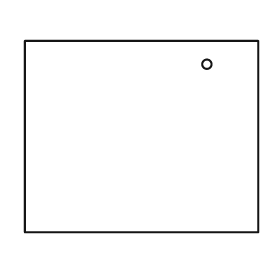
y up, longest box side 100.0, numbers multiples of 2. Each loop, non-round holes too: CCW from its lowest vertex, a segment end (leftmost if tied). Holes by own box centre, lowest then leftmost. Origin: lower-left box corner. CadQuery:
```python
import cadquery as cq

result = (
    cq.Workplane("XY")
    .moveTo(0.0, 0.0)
    .lineTo(100.0, 0.0)
    .lineTo(100.0, 82.0)
    .lineTo(0.0, 82.0)
    .close()
    .moveTo(78.0, 72.0)
    .circle(2.0)
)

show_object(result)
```